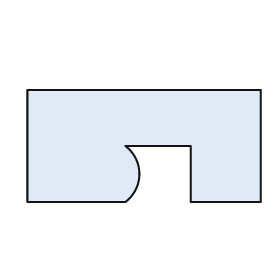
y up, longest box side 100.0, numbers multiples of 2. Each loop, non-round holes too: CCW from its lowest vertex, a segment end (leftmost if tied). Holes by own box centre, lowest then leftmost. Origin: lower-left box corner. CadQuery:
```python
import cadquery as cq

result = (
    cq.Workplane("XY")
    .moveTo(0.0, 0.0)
    .lineTo(42.0, 0.0)
    .threePointArc((48.0, 12.0), (42.0, 24.0))
    .lineTo(70.0, 24.0)
    .lineTo(70.0, 0.0)
    .lineTo(100.0, 0.0)
    .lineTo(100.0, 48.0)
    .lineTo(0.0, 48.0)
    .close()
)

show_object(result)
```